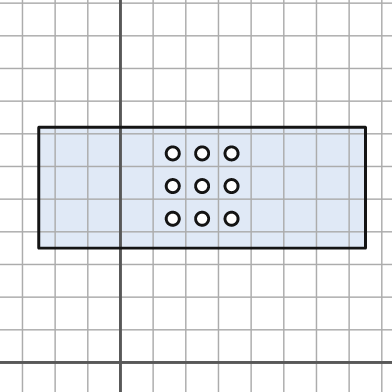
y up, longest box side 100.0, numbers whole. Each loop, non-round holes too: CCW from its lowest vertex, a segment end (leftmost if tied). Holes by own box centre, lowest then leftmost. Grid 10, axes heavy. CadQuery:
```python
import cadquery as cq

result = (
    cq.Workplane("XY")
    .moveTo(-25.0, 35.0)
    .lineTo(75.0, 35.0)
    .lineTo(75.0, 72.0)
    .lineTo(-25.0, 72.0)
    .close()
    .moveTo(16.0, 44.0)
    .circle(2.0)
    .moveTo(25.0, 44.0)
    .circle(2.0)
    .moveTo(34.0, 44.0)
    .circle(2.0)
    .moveTo(16.0, 54.0)
    .circle(2.0)
    .moveTo(25.0, 54.0)
    .circle(2.0)
    .moveTo(34.0, 54.0)
    .circle(2.0)
    .moveTo(16.0, 64.0)
    .circle(2.0)
    .moveTo(25.0, 64.0)
    .circle(2.0)
    .moveTo(34.0, 64.0)
    .circle(2.0)
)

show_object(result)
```